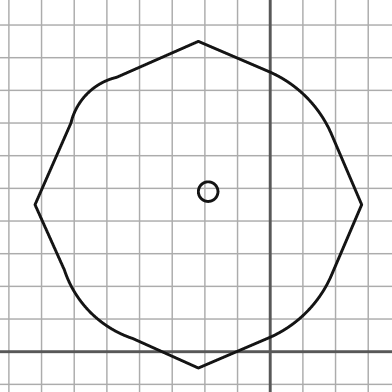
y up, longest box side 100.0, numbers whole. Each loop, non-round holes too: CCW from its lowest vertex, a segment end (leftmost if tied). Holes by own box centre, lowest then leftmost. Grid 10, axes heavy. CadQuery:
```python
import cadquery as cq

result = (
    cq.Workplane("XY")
    .moveTo(-22.0, -5.0)
    .lineTo(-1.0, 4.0)
    .threePointArc((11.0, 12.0), (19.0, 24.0))
    .lineTo(28.0, 45.0)
    .lineTo(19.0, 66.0)
    .threePointArc((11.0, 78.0), (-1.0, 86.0))
    .lineTo(-22.0, 95.0)
    .lineTo(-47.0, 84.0)
    .threePointArc((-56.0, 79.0), (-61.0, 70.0))
    .lineTo(-72.0, 45.0)
    .lineTo(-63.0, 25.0)
    .threePointArc((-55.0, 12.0), (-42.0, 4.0))
    .close()
    .moveTo(-19.0, 49.0)
    .circle(3.0)
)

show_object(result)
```